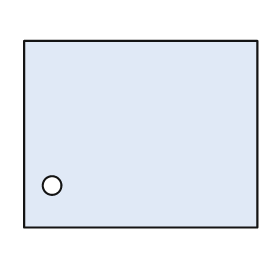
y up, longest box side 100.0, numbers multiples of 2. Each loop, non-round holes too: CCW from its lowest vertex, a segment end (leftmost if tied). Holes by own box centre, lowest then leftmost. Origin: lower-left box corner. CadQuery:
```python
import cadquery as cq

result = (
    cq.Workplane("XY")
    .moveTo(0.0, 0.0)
    .lineTo(100.0, 0.0)
    .lineTo(100.0, 80.0)
    .lineTo(0.0, 80.0)
    .close()
    .moveTo(12.0, 18.0)
    .circle(4.0)
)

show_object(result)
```